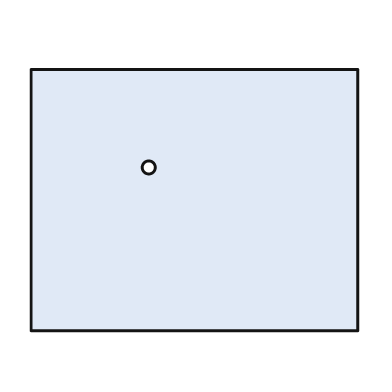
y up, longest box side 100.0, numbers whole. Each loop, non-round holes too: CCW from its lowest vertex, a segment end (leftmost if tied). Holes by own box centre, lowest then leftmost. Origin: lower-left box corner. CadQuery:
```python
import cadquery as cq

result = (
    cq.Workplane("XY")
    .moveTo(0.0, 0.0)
    .lineTo(100.0, 0.0)
    .lineTo(100.0, 80.0)
    .lineTo(0.0, 80.0)
    .close()
    .moveTo(36.0, 50.0)
    .circle(2.0)
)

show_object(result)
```